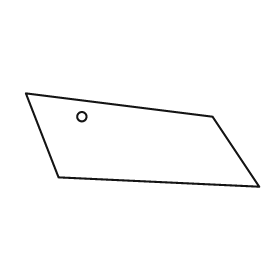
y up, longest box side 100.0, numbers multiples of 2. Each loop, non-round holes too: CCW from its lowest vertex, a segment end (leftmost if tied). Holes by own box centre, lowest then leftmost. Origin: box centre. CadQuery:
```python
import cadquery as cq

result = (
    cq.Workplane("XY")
    .moveTo(50.0, -20.0)
    .lineTo(30.0, 10.0)
    .lineTo(-50.0, 20.0)
    .lineTo(-36.0, -16.0)
    .close()
    .moveTo(-26.0, 10.0)
    .circle(2.0)
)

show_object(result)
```